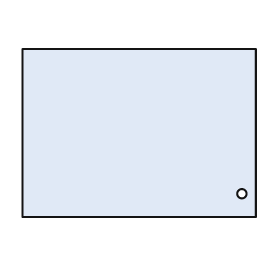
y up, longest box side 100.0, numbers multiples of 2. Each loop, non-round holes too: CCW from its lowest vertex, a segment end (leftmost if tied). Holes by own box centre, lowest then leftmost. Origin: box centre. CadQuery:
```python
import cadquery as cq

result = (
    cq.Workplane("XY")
    .moveTo(-50.0, -36.0)
    .lineTo(50.0, -36.0)
    .lineTo(50.0, 36.0)
    .lineTo(-50.0, 36.0)
    .close()
    .moveTo(44.0, -26.0)
    .circle(2.0)
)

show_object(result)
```